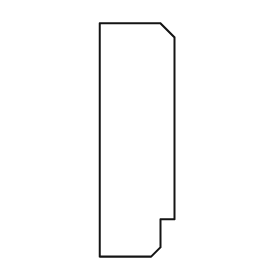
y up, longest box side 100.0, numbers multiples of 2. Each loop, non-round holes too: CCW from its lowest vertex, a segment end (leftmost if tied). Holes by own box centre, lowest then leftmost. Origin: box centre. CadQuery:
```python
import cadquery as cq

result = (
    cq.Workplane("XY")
    .moveTo(-16.0, -50.0)
    .lineTo(6.0, -50.0)
    .lineTo(10.0, -46.0)
    .lineTo(10.0, -34.0)
    .lineTo(16.0, -34.0)
    .lineTo(16.0, 44.0)
    .lineTo(10.0, 50.0)
    .lineTo(-16.0, 50.0)
    .close()
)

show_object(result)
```